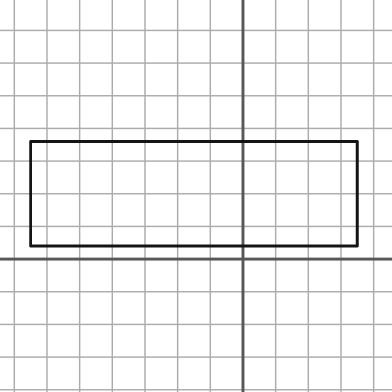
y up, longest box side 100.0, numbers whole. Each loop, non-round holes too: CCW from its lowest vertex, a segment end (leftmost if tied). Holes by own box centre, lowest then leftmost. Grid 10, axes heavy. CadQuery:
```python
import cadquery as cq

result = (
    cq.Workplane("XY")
    .moveTo(-65.0, 4.0)
    .lineTo(35.0, 4.0)
    .lineTo(35.0, 36.0)
    .lineTo(-65.0, 36.0)
    .close()
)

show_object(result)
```